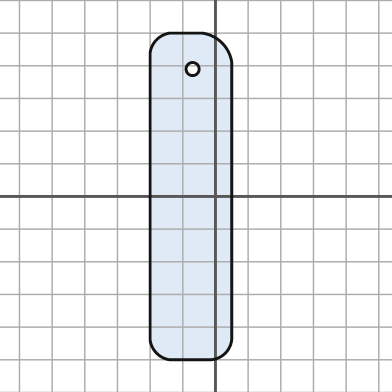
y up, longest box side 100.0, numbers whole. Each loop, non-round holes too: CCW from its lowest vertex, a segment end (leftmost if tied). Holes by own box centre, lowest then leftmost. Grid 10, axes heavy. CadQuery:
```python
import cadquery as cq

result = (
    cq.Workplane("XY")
    .moveTo(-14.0, -50.0)
    .lineTo(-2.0, -50.0)
    .threePointArc((3.0, -48.0), (5.0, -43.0))
    .lineTo(5.0, 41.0)
    .threePointArc((2.0, 47.0), (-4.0, 50.0))
    .lineTo(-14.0, 50.0)
    .threePointArc((-18.0, 48.0), (-20.0, 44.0))
    .lineTo(-20.0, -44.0)
    .threePointArc((-18.0, -48.0), (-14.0, -50.0))
    .close()
    .moveTo(-7.0, 39.0)
    .circle(2.0)
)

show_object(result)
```